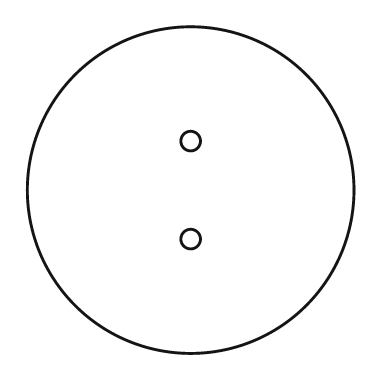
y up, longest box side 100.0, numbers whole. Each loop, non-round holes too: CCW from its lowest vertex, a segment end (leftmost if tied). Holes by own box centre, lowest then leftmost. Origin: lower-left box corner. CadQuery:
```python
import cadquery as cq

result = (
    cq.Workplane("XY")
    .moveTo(50.0, 50.0)
    .circle(50.0)
    .moveTo(50.0, 35.0)
    .circle(3.0)
    .moveTo(50.0, 65.0)
    .circle(3.0)
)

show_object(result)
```